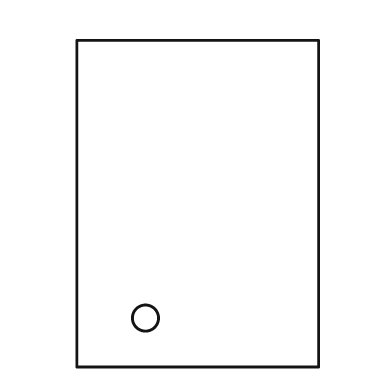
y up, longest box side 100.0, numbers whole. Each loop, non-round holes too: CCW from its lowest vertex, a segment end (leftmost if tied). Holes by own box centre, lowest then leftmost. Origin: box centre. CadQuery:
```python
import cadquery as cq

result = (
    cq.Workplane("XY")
    .moveTo(-37.0, -50.0)
    .lineTo(37.0, -50.0)
    .lineTo(37.0, 50.0)
    .lineTo(-37.0, 50.0)
    .close()
    .moveTo(-16.0, -35.0)
    .circle(4.0)
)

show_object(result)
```